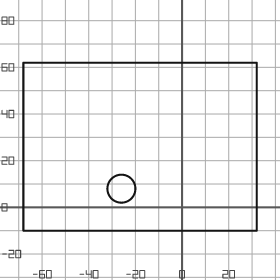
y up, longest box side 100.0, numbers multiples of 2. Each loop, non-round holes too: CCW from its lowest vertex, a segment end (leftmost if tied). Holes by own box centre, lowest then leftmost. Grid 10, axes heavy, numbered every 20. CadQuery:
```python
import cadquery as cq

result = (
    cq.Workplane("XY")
    .moveTo(-68.0, -10.0)
    .lineTo(32.0, -10.0)
    .lineTo(32.0, 62.0)
    .lineTo(-68.0, 62.0)
    .close()
    .moveTo(-26.0, 8.0)
    .circle(6.0)
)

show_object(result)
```